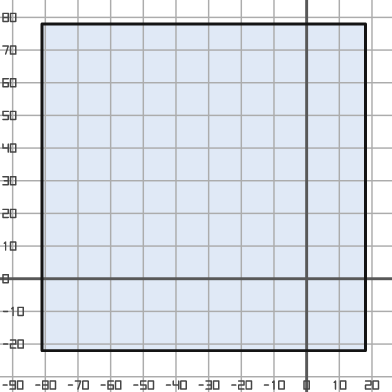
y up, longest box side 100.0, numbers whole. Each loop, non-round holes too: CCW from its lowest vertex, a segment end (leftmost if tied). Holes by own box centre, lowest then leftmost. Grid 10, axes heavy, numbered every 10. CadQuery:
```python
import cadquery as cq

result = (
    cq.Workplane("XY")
    .moveTo(-81.0, -22.0)
    .lineTo(18.0, -22.0)
    .lineTo(18.0, 78.0)
    .lineTo(-81.0, 78.0)
    .close()
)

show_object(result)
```